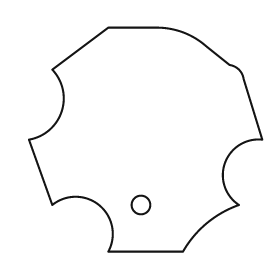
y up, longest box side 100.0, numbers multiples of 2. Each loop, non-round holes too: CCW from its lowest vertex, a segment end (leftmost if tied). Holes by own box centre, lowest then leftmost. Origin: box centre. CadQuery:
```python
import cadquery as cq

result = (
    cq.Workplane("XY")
    .moveTo(-16.0, -48.0)
    .lineTo(16.0, -48.0)
    .threePointArc((26.0, -36.0), (40.0, -28.0))
    .threePointArc((34.0, -10.0), (50.0, 0.0))
    .lineTo(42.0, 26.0)
    .threePointArc((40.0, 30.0), (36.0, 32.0))
    .lineTo(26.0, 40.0)
    .threePointArc((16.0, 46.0), (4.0, 48.0))
    .lineTo(-16.0, 48.0)
    .lineTo(-40.0, 30.0)
    .threePointArc((-36.0, 12.0), (-50.0, 0.0))
    .lineTo(-40.0, -28.0)
    .threePointArc((-20.0, -28.0), (-16.0, -48.0))
    .close()
    .moveTo(-2.0, -28.0)
    .circle(4.0)
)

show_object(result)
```